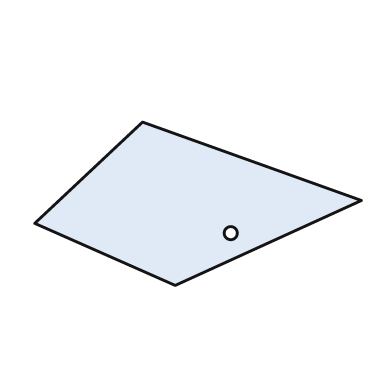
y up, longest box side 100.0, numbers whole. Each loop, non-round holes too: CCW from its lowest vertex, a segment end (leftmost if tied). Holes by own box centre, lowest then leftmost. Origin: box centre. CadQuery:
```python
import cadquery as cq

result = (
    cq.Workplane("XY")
    .moveTo(-7.0, -25.0)
    .lineTo(50.0, 1.0)
    .lineTo(-17.0, 25.0)
    .lineTo(-50.0, -6.0)
    .close()
    .moveTo(10.0, -9.0)
    .circle(2.0)
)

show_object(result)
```